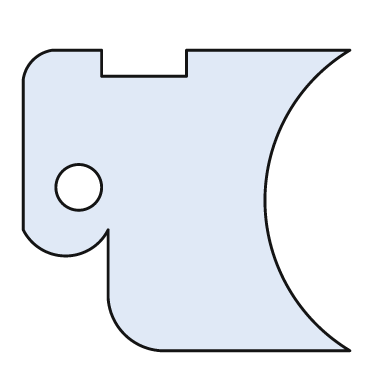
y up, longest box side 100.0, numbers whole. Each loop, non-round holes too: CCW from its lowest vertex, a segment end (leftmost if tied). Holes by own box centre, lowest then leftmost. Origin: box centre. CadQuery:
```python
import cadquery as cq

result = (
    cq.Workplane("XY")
    .moveTo(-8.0, -46.0)
    .lineTo(50.0, -46.0)
    .threePointArc((24.0, 0.0), (50.0, 46.0))
    .lineTo(0.0, 46.0)
    .lineTo(0.0, 38.0)
    .lineTo(-26.0, 38.0)
    .lineTo(-26.0, 46.0)
    .lineTo(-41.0, 46.0)
    .threePointArc((-47.0, 43.0), (-50.0, 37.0))
    .lineTo(-50.0, -9.0)
    .threePointArc((-37.0, -17.0), (-24.0, -9.0))
    .lineTo(-24.0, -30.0)
    .threePointArc((-19.0, -41.0), (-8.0, -46.0))
    .close()
    .moveTo(-33.0, 4.0)
    .circle(7.0)
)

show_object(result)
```